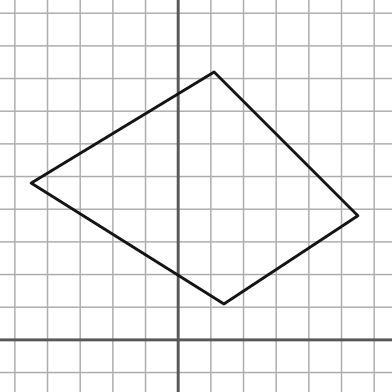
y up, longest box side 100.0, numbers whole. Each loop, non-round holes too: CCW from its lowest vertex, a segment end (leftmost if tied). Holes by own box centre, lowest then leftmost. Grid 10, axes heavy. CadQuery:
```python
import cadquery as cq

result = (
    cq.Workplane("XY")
    .moveTo(14.0, 11.0)
    .lineTo(55.0, 38.0)
    .lineTo(11.0, 82.0)
    .lineTo(-45.0, 48.0)
    .close()
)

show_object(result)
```